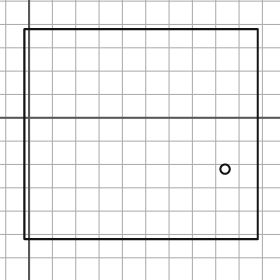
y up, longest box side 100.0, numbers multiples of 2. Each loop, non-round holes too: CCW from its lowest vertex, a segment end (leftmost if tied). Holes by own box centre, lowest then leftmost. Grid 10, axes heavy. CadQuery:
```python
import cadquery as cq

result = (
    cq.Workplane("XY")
    .moveTo(-2.0, -52.0)
    .lineTo(98.0, -52.0)
    .lineTo(98.0, 38.0)
    .lineTo(-2.0, 38.0)
    .close()
    .moveTo(84.0, -22.0)
    .circle(2.0)
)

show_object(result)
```